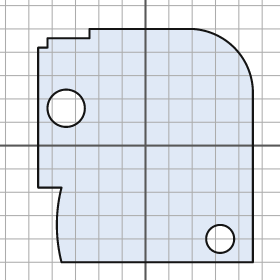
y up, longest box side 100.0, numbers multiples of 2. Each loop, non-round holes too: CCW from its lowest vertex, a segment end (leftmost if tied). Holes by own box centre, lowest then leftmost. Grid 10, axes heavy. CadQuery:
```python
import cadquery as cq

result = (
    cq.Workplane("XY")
    .moveTo(-36.0, -50.0)
    .lineTo(46.0, -50.0)
    .lineTo(46.0, 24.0)
    .threePointArc((38.0, 42.0), (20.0, 50.0))
    .lineTo(-24.0, 50.0)
    .lineTo(-24.0, 46.0)
    .lineTo(-42.0, 46.0)
    .lineTo(-42.0, 42.0)
    .lineTo(-46.0, 42.0)
    .lineTo(-46.0, -18.0)
    .lineTo(-36.0, -18.0)
    .threePointArc((-38.0, -34.0), (-36.0, -50.0))
    .close()
    .moveTo(32.0, -40.0)
    .circle(6.0)
    .moveTo(-34.0, 16.0)
    .circle(8.0)
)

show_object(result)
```